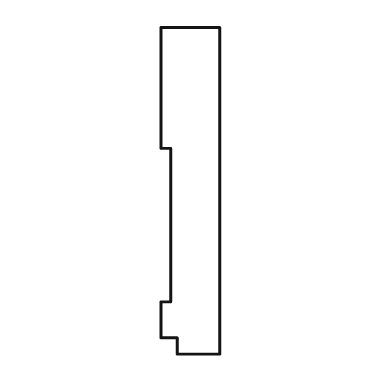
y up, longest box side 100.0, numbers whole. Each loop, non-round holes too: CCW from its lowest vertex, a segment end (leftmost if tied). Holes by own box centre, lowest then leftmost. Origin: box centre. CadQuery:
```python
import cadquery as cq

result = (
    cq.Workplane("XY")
    .moveTo(-4.0, -50.0)
    .lineTo(9.0, -50.0)
    .lineTo(9.0, 50.0)
    .lineTo(-9.0, 50.0)
    .lineTo(-9.0, 13.0)
    .lineTo(-6.0, 13.0)
    .lineTo(-6.0, -34.0)
    .lineTo(-9.0, -34.0)
    .lineTo(-9.0, -45.0)
    .lineTo(-4.0, -45.0)
    .close()
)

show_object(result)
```